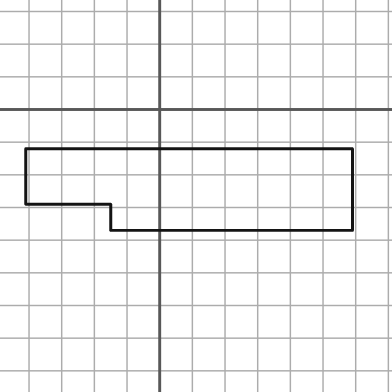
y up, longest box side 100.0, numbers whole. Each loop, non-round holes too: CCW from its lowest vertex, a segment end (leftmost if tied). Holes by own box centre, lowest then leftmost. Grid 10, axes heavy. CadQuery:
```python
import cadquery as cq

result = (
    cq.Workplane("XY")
    .moveTo(-15.0, -37.0)
    .lineTo(59.0, -37.0)
    .lineTo(59.0, -12.0)
    .lineTo(-41.0, -12.0)
    .lineTo(-41.0, -29.0)
    .lineTo(-15.0, -29.0)
    .close()
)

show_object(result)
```